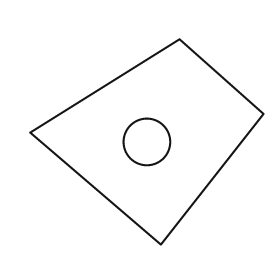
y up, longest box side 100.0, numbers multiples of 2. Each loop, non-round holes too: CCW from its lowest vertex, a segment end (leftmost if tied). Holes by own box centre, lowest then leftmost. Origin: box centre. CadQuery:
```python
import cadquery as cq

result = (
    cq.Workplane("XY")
    .moveTo(6.0, -44.0)
    .lineTo(50.0, 12.0)
    .lineTo(14.0, 44.0)
    .lineTo(-50.0, 4.0)
    .close()
    .moveTo(0.0, 0.0)
    .circle(10.0)
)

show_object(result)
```